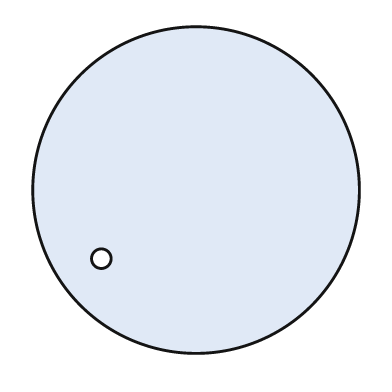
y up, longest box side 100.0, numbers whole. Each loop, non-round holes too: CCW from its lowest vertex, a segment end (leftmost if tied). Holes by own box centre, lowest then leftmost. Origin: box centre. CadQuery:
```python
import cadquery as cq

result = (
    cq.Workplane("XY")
    .moveTo(0.0, 0.0)
    .circle(50.0)
    .moveTo(-29.0, -21.0)
    .circle(3.0)
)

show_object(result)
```